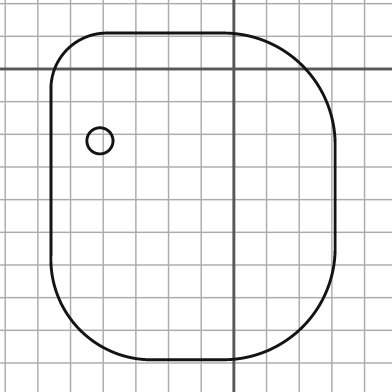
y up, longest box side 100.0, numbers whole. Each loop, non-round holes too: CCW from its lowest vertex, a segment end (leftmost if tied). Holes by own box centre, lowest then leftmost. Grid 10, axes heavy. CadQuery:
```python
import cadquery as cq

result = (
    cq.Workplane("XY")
    .moveTo(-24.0, -89.0)
    .lineTo(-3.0, -89.0)
    .threePointArc((21.0, -79.0), (31.0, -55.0))
    .lineTo(31.0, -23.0)
    .threePointArc((21.0, 1.0), (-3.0, 11.0))
    .lineTo(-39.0, 11.0)
    .threePointArc((-51.0, 6.0), (-56.0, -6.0))
    .lineTo(-56.0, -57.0)
    .threePointArc((-47.0, -80.0), (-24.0, -89.0))
    .close()
    .moveTo(-41.0, -22.0)
    .circle(4.0)
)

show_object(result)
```